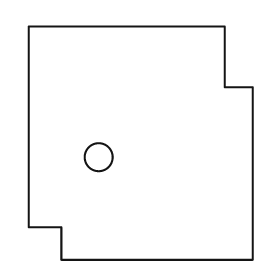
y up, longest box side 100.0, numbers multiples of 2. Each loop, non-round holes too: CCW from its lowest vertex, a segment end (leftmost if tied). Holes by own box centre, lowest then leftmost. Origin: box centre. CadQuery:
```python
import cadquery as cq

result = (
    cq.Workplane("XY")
    .moveTo(-34.0, -50.0)
    .lineTo(48.0, -50.0)
    .lineTo(48.0, 24.0)
    .lineTo(36.0, 24.0)
    .lineTo(36.0, 50.0)
    .lineTo(-48.0, 50.0)
    .lineTo(-48.0, -36.0)
    .lineTo(-34.0, -36.0)
    .close()
    .moveTo(-18.0, -6.0)
    .circle(6.0)
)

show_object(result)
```